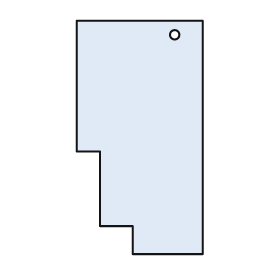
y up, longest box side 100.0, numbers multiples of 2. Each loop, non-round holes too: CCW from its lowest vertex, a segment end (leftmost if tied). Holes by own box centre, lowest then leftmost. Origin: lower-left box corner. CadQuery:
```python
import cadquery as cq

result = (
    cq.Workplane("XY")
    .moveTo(24.0, 0.0)
    .lineTo(54.0, 0.0)
    .lineTo(54.0, 100.0)
    .lineTo(0.0, 100.0)
    .lineTo(0.0, 44.0)
    .lineTo(10.0, 44.0)
    .lineTo(10.0, 12.0)
    .lineTo(24.0, 12.0)
    .close()
    .moveTo(42.0, 94.0)
    .circle(2.0)
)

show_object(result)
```